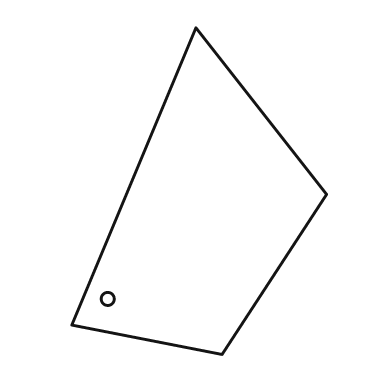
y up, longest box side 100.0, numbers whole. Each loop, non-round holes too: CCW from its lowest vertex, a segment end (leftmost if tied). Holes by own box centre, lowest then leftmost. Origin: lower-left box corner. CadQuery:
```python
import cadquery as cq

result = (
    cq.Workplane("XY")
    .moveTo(46.0, 0.0)
    .lineTo(78.0, 49.0)
    .lineTo(38.0, 100.0)
    .lineTo(0.0, 9.0)
    .close()
    .moveTo(11.0, 17.0)
    .circle(2.0)
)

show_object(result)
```